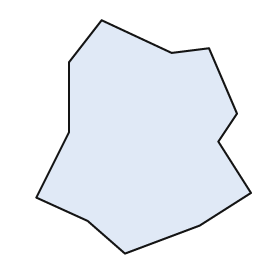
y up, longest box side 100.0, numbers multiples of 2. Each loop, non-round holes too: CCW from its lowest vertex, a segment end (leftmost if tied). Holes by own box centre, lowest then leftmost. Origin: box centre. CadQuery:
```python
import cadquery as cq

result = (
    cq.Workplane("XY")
    .moveTo(-8.0, -50.0)
    .lineTo(24.0, -38.0)
    .lineTo(46.0, -24.0)
    .lineTo(32.0, -2.0)
    .lineTo(40.0, 10.0)
    .lineTo(28.0, 38.0)
    .lineTo(12.0, 36.0)
    .lineTo(-18.0, 50.0)
    .lineTo(-32.0, 32.0)
    .lineTo(-32.0, 2.0)
    .lineTo(-46.0, -26.0)
    .lineTo(-24.0, -36.0)
    .close()
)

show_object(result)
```